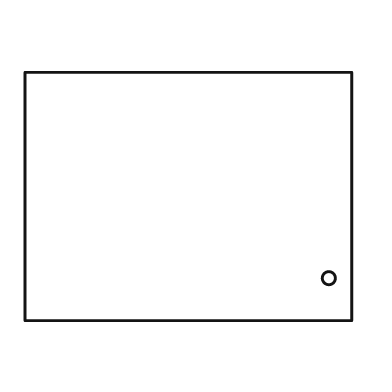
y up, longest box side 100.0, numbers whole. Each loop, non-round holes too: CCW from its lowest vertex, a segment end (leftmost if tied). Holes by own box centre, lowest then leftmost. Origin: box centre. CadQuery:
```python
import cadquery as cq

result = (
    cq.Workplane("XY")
    .moveTo(-50.0, -38.0)
    .lineTo(50.0, -38.0)
    .lineTo(50.0, 38.0)
    .lineTo(-50.0, 38.0)
    .close()
    .moveTo(43.0, -25.0)
    .circle(2.0)
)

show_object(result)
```